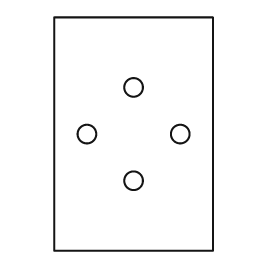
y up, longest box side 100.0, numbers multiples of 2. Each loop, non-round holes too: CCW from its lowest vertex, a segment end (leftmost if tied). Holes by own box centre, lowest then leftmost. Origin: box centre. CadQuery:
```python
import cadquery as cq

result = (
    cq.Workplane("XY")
    .moveTo(-34.0, -50.0)
    .lineTo(34.0, -50.0)
    .lineTo(34.0, 50.0)
    .lineTo(-34.0, 50.0)
    .close()
    .moveTo(0.0, -20.0)
    .circle(4.0)
    .moveTo(-20.0, 0.0)
    .circle(4.0)
    .moveTo(20.0, 0.0)
    .circle(4.0)
    .moveTo(0.0, 20.0)
    .circle(4.0)
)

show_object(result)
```